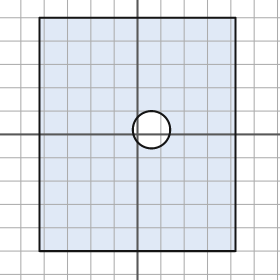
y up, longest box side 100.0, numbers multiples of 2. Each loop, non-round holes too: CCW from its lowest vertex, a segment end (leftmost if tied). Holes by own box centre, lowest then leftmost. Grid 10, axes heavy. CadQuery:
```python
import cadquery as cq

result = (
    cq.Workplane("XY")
    .moveTo(-42.0, -50.0)
    .lineTo(42.0, -50.0)
    .lineTo(42.0, 50.0)
    .lineTo(-42.0, 50.0)
    .close()
    .moveTo(6.0, 2.0)
    .circle(8.0)
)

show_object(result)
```